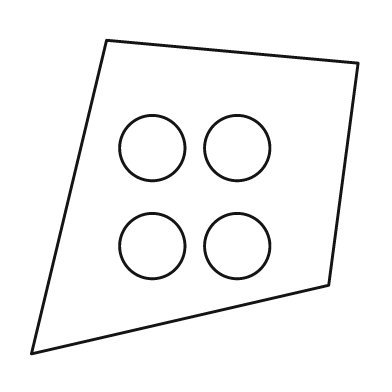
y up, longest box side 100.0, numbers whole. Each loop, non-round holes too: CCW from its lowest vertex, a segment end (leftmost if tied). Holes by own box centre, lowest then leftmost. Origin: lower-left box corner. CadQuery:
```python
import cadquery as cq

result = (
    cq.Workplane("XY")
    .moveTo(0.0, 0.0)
    .lineTo(91.0, 21.0)
    .lineTo(100.0, 89.0)
    .lineTo(23.0, 96.0)
    .close()
    .moveTo(37.0, 33.0)
    .circle(10.0)
    .moveTo(63.0, 33.0)
    .circle(10.0)
    .moveTo(37.0, 63.0)
    .circle(10.0)
    .moveTo(63.0, 63.0)
    .circle(10.0)
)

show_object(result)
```